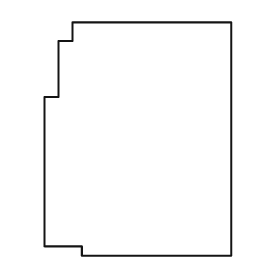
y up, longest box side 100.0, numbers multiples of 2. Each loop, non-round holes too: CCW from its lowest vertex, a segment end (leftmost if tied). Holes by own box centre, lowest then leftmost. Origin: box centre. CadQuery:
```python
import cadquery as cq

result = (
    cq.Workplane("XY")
    .moveTo(-24.0, -50.0)
    .lineTo(40.0, -50.0)
    .lineTo(40.0, 50.0)
    .lineTo(-28.0, 50.0)
    .lineTo(-28.0, 42.0)
    .lineTo(-34.0, 42.0)
    .lineTo(-34.0, 18.0)
    .lineTo(-40.0, 18.0)
    .lineTo(-40.0, -46.0)
    .lineTo(-24.0, -46.0)
    .close()
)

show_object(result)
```